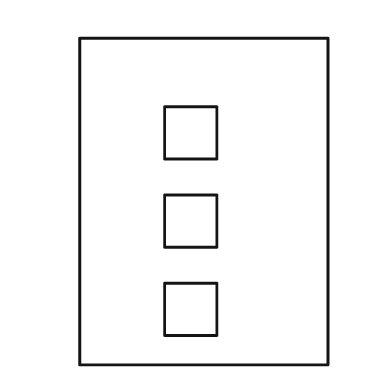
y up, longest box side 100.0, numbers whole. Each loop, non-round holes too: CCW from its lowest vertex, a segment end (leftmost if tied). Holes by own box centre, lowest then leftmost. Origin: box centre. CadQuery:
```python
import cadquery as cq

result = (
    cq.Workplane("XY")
    .moveTo(-38.0, -50.0)
    .lineTo(38.0, -50.0)
    .lineTo(38.0, 50.0)
    .lineTo(-38.0, 50.0)
    .close()
    .moveTo(-12.0, -41.0)
    .lineTo(4.0, -41.0)
    .lineTo(4.0, -25.0)
    .lineTo(-12.0, -25.0)
    .close()
    .moveTo(-12.0, -14.0)
    .lineTo(4.0, -14.0)
    .lineTo(4.0, 2.0)
    .lineTo(-12.0, 2.0)
    .close()
    .moveTo(-12.0, 13.0)
    .lineTo(4.0, 13.0)
    .lineTo(4.0, 29.0)
    .lineTo(-12.0, 29.0)
    .close()
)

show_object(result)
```